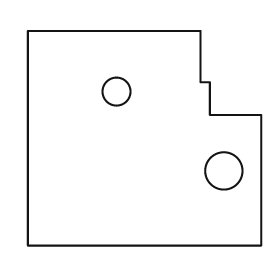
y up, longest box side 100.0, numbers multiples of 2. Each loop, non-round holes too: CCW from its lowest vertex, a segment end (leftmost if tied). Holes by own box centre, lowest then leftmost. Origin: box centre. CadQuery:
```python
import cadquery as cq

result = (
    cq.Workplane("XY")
    .moveTo(-50.0, -46.0)
    .lineTo(50.0, -46.0)
    .lineTo(50.0, 10.0)
    .lineTo(28.0, 10.0)
    .lineTo(28.0, 24.0)
    .lineTo(24.0, 24.0)
    .lineTo(24.0, 46.0)
    .lineTo(-50.0, 46.0)
    .close()
    .moveTo(34.0, -14.0)
    .circle(8.0)
    .moveTo(-12.0, 20.0)
    .circle(6.0)
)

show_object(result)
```